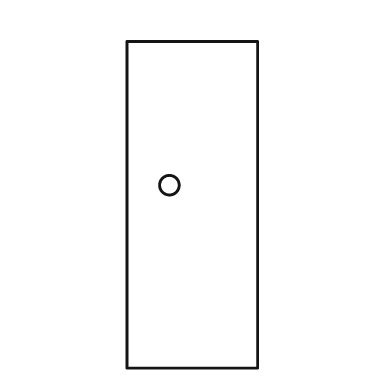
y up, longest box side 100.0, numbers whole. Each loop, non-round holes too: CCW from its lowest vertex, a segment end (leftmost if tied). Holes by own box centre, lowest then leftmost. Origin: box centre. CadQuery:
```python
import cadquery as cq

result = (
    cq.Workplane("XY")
    .moveTo(-20.0, -50.0)
    .lineTo(20.0, -50.0)
    .lineTo(20.0, 50.0)
    .lineTo(-20.0, 50.0)
    .close()
    .moveTo(-7.0, 6.0)
    .circle(3.0)
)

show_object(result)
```